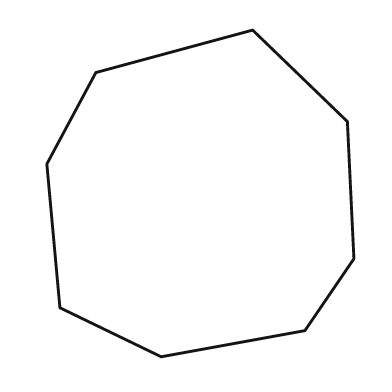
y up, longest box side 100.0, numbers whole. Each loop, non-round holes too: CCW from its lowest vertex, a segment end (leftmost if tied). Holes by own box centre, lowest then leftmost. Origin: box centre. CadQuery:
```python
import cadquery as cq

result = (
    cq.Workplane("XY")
    .moveTo(-12.0, -50.0)
    .lineTo(32.0, -42.0)
    .lineTo(47.0, -20.0)
    .lineTo(45.0, 22.0)
    .lineTo(16.0, 50.0)
    .lineTo(-32.0, 37.0)
    .lineTo(-47.0, 9.0)
    .lineTo(-43.0, -35.0)
    .close()
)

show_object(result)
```